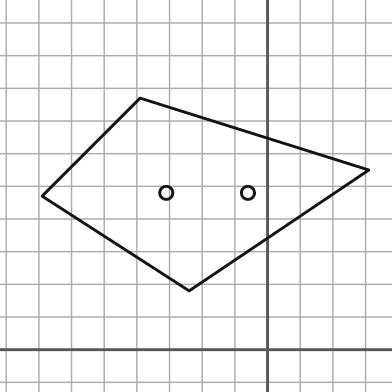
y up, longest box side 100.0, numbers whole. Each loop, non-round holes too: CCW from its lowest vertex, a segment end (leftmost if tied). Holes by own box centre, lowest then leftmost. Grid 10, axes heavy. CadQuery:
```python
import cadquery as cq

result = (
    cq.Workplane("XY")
    .moveTo(-24.0, 18.0)
    .lineTo(31.0, 55.0)
    .lineTo(-39.0, 77.0)
    .lineTo(-69.0, 47.0)
    .close()
    .moveTo(-31.0, 48.0)
    .circle(2.0)
    .moveTo(-6.0, 48.0)
    .circle(2.0)
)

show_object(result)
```